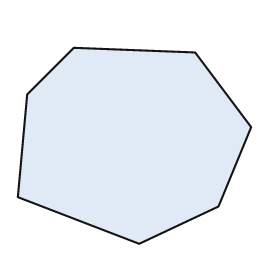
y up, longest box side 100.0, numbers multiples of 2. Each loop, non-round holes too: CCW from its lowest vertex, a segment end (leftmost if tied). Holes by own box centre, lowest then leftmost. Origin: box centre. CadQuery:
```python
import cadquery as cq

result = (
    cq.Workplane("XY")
    .moveTo(2.0, -42.0)
    .lineTo(36.0, -26.0)
    .lineTo(50.0, 8.0)
    .lineTo(26.0, 40.0)
    .lineTo(-26.0, 42.0)
    .lineTo(-46.0, 22.0)
    .lineTo(-50.0, -22.0)
    .close()
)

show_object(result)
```